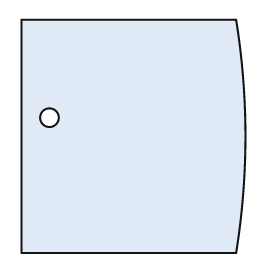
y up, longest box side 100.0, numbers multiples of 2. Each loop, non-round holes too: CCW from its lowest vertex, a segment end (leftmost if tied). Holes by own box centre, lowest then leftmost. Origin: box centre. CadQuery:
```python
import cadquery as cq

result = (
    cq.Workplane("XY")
    .moveTo(-48.0, -50.0)
    .lineTo(44.0, -50.0)
    .threePointArc((48.0, 0.0), (44.0, 50.0))
    .lineTo(-48.0, 50.0)
    .close()
    .moveTo(-36.0, 8.0)
    .circle(4.0)
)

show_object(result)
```